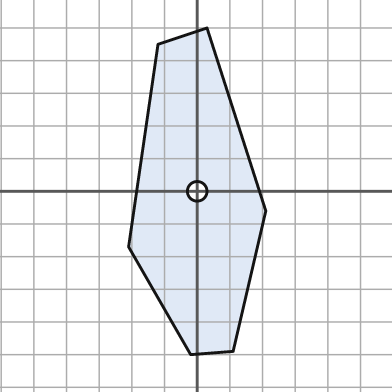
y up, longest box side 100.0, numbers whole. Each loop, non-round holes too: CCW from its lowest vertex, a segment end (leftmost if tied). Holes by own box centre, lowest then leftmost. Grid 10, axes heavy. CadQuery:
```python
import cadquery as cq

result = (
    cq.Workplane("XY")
    .moveTo(-2.0, -50.0)
    .lineTo(11.0, -49.0)
    .lineTo(21.0, -6.0)
    .lineTo(3.0, 50.0)
    .lineTo(-12.0, 45.0)
    .lineTo(-21.0, -17.0)
    .close()
    .moveTo(0.0, 0.0)
    .circle(3.0)
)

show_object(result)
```